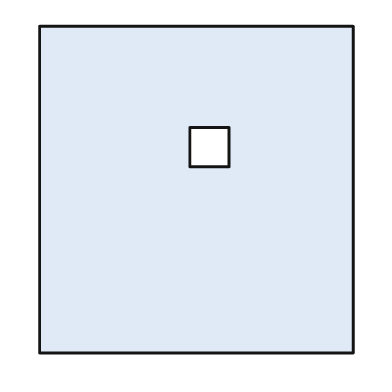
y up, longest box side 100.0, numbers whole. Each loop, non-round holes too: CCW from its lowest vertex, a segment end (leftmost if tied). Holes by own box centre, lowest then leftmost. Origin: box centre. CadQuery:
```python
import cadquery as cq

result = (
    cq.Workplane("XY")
    .moveTo(-48.0, -50.0)
    .lineTo(48.0, -50.0)
    .lineTo(48.0, 50.0)
    .lineTo(-48.0, 50.0)
    .close()
    .moveTo(-2.0, 7.0)
    .lineTo(10.0, 7.0)
    .lineTo(10.0, 19.0)
    .lineTo(-2.0, 19.0)
    .close()
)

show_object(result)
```